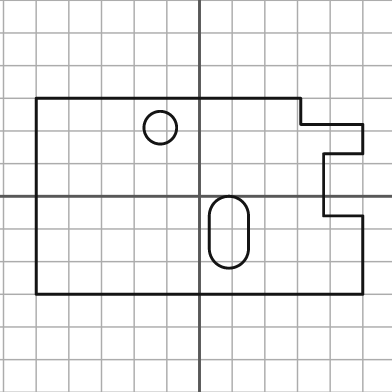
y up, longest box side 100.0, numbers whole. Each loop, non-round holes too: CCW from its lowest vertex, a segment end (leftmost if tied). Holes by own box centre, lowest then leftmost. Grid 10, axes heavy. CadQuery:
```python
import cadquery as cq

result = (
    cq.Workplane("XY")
    .moveTo(-50.0, -30.0)
    .lineTo(50.0, -30.0)
    .lineTo(50.0, -6.0)
    .lineTo(38.0, -6.0)
    .lineTo(38.0, 13.0)
    .lineTo(50.0, 13.0)
    .lineTo(50.0, 22.0)
    .lineTo(31.0, 22.0)
    .lineTo(31.0, 30.0)
    .lineTo(-50.0, 30.0)
    .close()
    .moveTo(3.0, -16.0)
    .threePointArc((9.0, -22.0), (15.0, -16.0))
    .lineTo(15.0, -6.0)
    .threePointArc((9.0, 0.0), (3.0, -6.0))
    .close()
    .moveTo(-12.0, 21.0)
    .circle(5.0)
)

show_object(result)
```